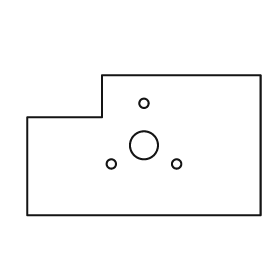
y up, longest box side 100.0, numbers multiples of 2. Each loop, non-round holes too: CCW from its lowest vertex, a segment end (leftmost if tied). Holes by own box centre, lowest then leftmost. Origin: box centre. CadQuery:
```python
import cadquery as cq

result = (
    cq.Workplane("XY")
    .moveTo(-50.0, -30.0)
    .lineTo(50.0, -30.0)
    .lineTo(50.0, 30.0)
    .lineTo(-18.0, 30.0)
    .lineTo(-18.0, 12.0)
    .lineTo(-50.0, 12.0)
    .close()
    .moveTo(-14.0, -8.0)
    .circle(2.0)
    .moveTo(14.0, -8.0)
    .circle(2.0)
    .moveTo(0.0, 0.0)
    .circle(6.0)
    .moveTo(0.0, 18.0)
    .circle(2.0)
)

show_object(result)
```